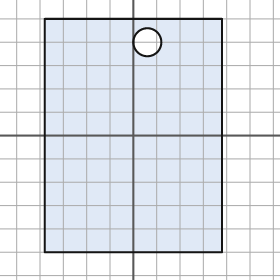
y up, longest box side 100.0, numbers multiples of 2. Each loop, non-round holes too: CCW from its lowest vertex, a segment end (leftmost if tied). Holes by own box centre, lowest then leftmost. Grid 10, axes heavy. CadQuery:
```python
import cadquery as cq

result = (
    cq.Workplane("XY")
    .moveTo(-38.0, -50.0)
    .lineTo(38.0, -50.0)
    .lineTo(38.0, 50.0)
    .lineTo(-38.0, 50.0)
    .close()
    .moveTo(6.0, 40.0)
    .circle(6.0)
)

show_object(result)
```